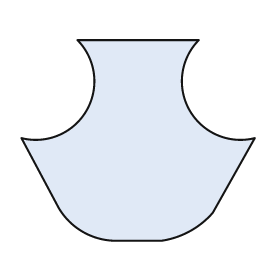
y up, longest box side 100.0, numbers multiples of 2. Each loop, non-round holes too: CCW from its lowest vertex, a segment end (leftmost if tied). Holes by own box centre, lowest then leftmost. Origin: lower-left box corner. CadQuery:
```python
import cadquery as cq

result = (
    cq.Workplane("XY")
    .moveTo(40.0, 0.0)
    .lineTo(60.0, 0.0)
    .threePointArc((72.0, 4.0), (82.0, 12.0))
    .lineTo(100.0, 44.0)
    .threePointArc((72.0, 56.0), (76.0, 86.0))
    .lineTo(24.0, 86.0)
    .threePointArc((28.0, 56.0), (0.0, 44.0))
    .lineTo(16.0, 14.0)
    .threePointArc((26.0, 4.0), (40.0, 0.0))
    .close()
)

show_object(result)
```